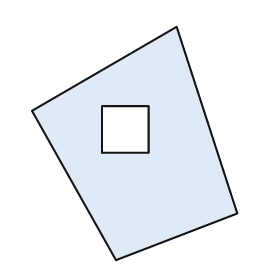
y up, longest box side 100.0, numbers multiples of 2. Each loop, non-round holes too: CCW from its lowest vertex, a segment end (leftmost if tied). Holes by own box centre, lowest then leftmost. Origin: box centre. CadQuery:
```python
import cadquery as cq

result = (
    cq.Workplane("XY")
    .moveTo(-8.0, -50.0)
    .lineTo(44.0, -30.0)
    .lineTo(18.0, 50.0)
    .lineTo(-44.0, 14.0)
    .close()
    .moveTo(-14.0, -4.0)
    .lineTo(6.0, -4.0)
    .lineTo(6.0, 16.0)
    .lineTo(-14.0, 16.0)
    .close()
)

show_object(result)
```